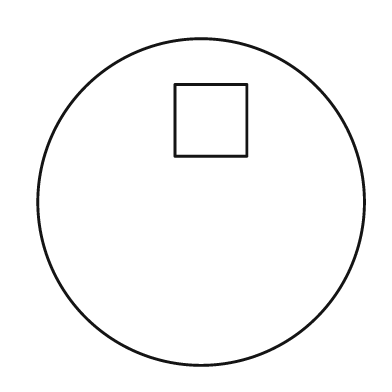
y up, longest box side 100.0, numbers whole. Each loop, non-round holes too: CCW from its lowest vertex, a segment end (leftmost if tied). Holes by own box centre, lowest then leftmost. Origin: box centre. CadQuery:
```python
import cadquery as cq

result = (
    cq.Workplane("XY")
    .moveTo(0.0, 0.0)
    .circle(50.0)
    .moveTo(-8.0, 14.0)
    .lineTo(14.0, 14.0)
    .lineTo(14.0, 36.0)
    .lineTo(-8.0, 36.0)
    .close()
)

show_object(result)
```